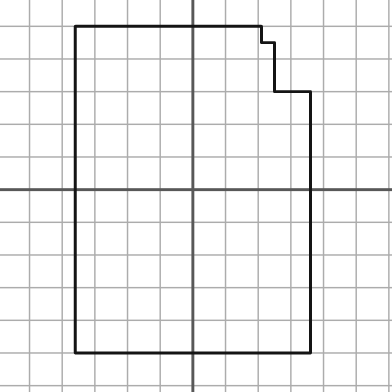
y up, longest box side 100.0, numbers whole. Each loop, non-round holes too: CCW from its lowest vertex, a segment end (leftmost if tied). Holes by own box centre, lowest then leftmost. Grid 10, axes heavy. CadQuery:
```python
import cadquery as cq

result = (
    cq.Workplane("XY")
    .moveTo(-36.0, -50.0)
    .lineTo(36.0, -50.0)
    .lineTo(36.0, 30.0)
    .lineTo(25.0, 30.0)
    .lineTo(25.0, 45.0)
    .lineTo(21.0, 45.0)
    .lineTo(21.0, 50.0)
    .lineTo(-36.0, 50.0)
    .close()
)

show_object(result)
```